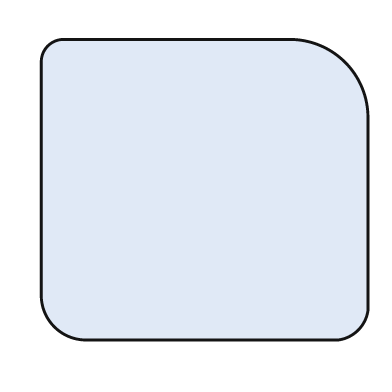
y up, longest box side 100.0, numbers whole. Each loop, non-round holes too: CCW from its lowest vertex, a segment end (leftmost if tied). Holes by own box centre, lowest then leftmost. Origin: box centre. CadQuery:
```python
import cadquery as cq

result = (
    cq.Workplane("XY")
    .moveTo(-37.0, -46.0)
    .lineTo(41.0, -46.0)
    .threePointArc((47.0, -43.0), (50.0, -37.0))
    .lineTo(50.0, 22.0)
    .threePointArc((43.0, 39.0), (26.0, 46.0))
    .lineTo(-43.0, 46.0)
    .threePointArc((-48.0, 44.0), (-50.0, 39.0))
    .lineTo(-50.0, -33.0)
    .threePointArc((-46.0, -42.0), (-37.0, -46.0))
    .close()
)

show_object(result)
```